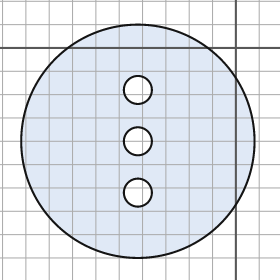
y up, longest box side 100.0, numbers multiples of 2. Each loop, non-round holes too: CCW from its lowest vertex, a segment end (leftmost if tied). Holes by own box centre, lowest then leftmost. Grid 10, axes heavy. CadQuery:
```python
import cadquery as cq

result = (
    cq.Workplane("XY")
    .moveTo(-42.0, -40.0)
    .circle(50.0)
    .moveTo(-42.0, -62.0)
    .circle(6.0)
    .moveTo(-42.0, -40.0)
    .circle(6.0)
    .moveTo(-42.0, -18.0)
    .circle(6.0)
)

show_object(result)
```